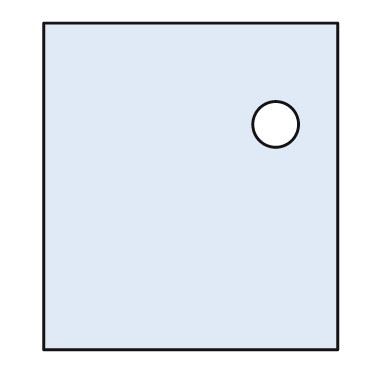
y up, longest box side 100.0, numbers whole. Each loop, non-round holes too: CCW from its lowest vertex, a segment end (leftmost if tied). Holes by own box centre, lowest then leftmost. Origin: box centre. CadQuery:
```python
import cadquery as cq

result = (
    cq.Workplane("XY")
    .moveTo(-45.0, -50.0)
    .lineTo(45.0, -50.0)
    .lineTo(45.0, 50.0)
    .lineTo(-45.0, 50.0)
    .close()
    .moveTo(26.0, 19.0)
    .circle(7.0)
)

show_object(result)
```